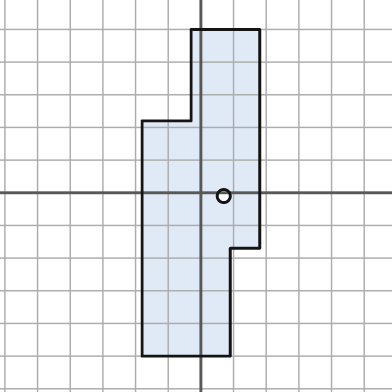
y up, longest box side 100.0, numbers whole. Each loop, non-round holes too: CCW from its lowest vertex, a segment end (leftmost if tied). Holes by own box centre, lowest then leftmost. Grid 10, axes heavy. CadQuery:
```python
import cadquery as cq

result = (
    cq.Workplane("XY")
    .moveTo(-18.0, -50.0)
    .lineTo(9.0, -50.0)
    .lineTo(9.0, -17.0)
    .lineTo(18.0, -17.0)
    .lineTo(18.0, 50.0)
    .lineTo(-3.0, 50.0)
    .lineTo(-3.0, 22.0)
    .lineTo(-18.0, 22.0)
    .close()
    .moveTo(7.0, -1.0)
    .circle(2.0)
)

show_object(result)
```